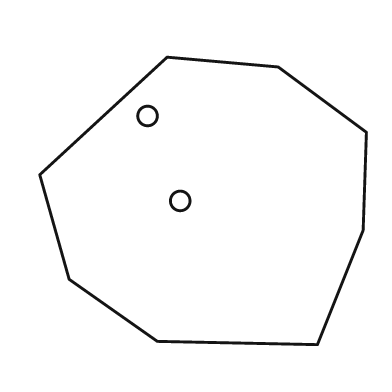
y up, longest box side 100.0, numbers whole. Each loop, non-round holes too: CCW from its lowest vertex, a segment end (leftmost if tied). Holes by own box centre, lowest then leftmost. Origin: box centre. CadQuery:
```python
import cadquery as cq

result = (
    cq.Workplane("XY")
    .moveTo(35.0, -44.0)
    .lineTo(49.0, -9.0)
    .lineTo(50.0, 21.0)
    .lineTo(23.0, 41.0)
    .lineTo(-11.0, 44.0)
    .lineTo(-50.0, 8.0)
    .lineTo(-41.0, -24.0)
    .lineTo(-14.0, -43.0)
    .close()
    .moveTo(-7.0, 0.0)
    .circle(3.0)
    .moveTo(-17.0, 26.0)
    .circle(3.0)
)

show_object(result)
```